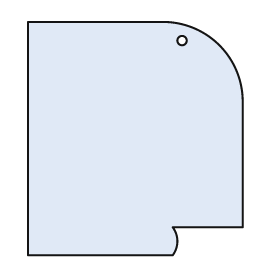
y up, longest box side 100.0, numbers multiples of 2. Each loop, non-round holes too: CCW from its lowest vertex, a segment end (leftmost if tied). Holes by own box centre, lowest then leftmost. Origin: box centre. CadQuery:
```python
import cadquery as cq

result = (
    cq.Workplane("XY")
    .moveTo(-46.0, -50.0)
    .lineTo(16.0, -50.0)
    .threePointArc((18.0, -44.0), (16.0, -38.0))
    .lineTo(46.0, -38.0)
    .lineTo(46.0, 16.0)
    .threePointArc((36.0, 40.0), (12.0, 50.0))
    .lineTo(-46.0, 50.0)
    .close()
    .moveTo(20.0, 42.0)
    .circle(2.0)
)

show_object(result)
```